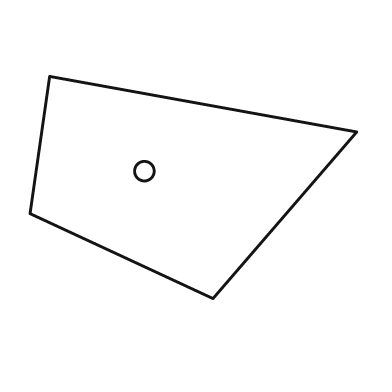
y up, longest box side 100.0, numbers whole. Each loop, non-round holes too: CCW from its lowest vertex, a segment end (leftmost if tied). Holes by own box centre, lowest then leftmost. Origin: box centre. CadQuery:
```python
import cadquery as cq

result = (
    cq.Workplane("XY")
    .moveTo(6.0, -34.0)
    .lineTo(50.0, 17.0)
    .lineTo(-44.0, 34.0)
    .lineTo(-50.0, -8.0)
    .close()
    .moveTo(-15.0, 5.0)
    .circle(3.0)
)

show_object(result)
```